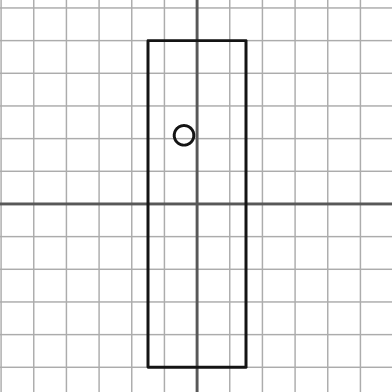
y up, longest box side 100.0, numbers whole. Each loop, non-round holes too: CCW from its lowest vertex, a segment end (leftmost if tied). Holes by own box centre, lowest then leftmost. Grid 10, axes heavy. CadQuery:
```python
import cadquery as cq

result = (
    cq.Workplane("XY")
    .moveTo(-15.0, -50.0)
    .lineTo(15.0, -50.0)
    .lineTo(15.0, 50.0)
    .lineTo(-15.0, 50.0)
    .close()
    .moveTo(-4.0, 21.0)
    .circle(3.0)
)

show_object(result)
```